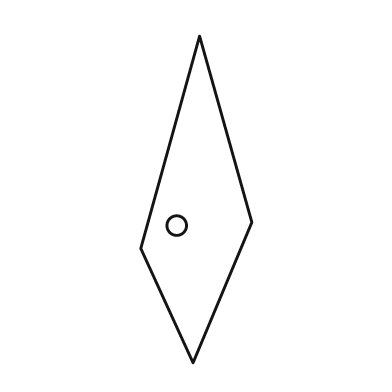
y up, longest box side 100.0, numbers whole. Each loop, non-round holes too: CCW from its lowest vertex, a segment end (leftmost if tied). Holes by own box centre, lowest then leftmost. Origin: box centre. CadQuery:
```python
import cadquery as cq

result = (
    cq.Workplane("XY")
    .moveTo(-1.0, -50.0)
    .lineTo(17.0, -7.0)
    .lineTo(1.0, 50.0)
    .lineTo(-17.0, -15.0)
    .close()
    .moveTo(-6.0, -8.0)
    .circle(3.0)
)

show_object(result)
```